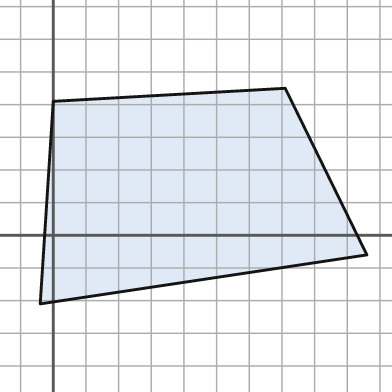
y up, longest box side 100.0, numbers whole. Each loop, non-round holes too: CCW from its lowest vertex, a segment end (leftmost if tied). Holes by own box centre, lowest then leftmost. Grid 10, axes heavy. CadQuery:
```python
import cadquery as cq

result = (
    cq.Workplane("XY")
    .moveTo(-4.0, -21.0)
    .lineTo(96.0, -6.0)
    .lineTo(71.0, 45.0)
    .lineTo(0.0, 41.0)
    .close()
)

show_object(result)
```